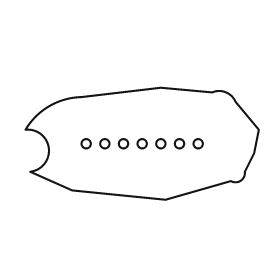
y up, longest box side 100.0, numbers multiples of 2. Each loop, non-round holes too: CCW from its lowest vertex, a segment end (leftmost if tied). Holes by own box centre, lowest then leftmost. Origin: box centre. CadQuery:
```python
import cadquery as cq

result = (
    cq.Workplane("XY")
    .moveTo(10.0, -24.0)
    .lineTo(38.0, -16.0)
    .threePointArc((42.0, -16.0), (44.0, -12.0))
    .lineTo(48.0, -4.0)
    .lineTo(50.0, 6.0)
    .lineTo(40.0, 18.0)
    .threePointArc((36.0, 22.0), (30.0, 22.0))
    .lineTo(8.0, 24.0)
    .lineTo(-26.0, 20.0)
    .threePointArc((-40.0, 16.0), (-50.0, 6.0))
    .threePointArc((-40.0, -2.0), (-48.0, -12.0))
    .lineTo(-30.0, -20.0)
    .close()
    .moveTo(-24.0, 0.0)
    .circle(2.0)
    .moveTo(-16.0, 0.0)
    .circle(2.0)
    .moveTo(-8.0, 0.0)
    .circle(2.0)
    .moveTo(0.0, 0.0)
    .circle(2.0)
    .moveTo(8.0, 0.0)
    .circle(2.0)
    .moveTo(16.0, 0.0)
    .circle(2.0)
    .moveTo(24.0, 0.0)
    .circle(2.0)
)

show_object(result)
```